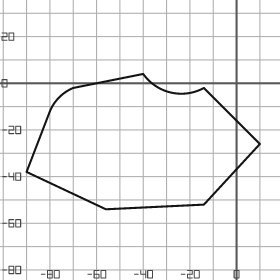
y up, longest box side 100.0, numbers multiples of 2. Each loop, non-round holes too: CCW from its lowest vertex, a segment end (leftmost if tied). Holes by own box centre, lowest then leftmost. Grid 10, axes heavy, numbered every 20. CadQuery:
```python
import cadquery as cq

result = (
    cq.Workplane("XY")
    .moveTo(-56.0, -54.0)
    .lineTo(-14.0, -52.0)
    .lineTo(10.0, -26.0)
    .lineTo(-14.0, -2.0)
    .threePointArc((-28.0, -4.0), (-40.0, 4.0))
    .lineTo(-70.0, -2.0)
    .threePointArc((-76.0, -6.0), (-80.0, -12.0))
    .lineTo(-90.0, -38.0)
    .close()
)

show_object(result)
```